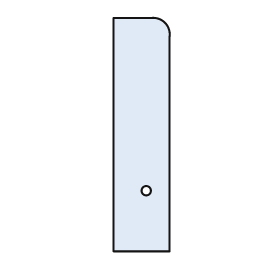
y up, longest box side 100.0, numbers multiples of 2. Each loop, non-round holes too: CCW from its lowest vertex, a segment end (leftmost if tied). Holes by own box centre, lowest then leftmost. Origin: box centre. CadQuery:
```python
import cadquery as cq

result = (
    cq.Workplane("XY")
    .moveTo(-12.0, -50.0)
    .lineTo(12.0, -50.0)
    .lineTo(12.0, 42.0)
    .threePointArc((10.0, 48.0), (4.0, 50.0))
    .lineTo(-12.0, 50.0)
    .close()
    .moveTo(2.0, -24.0)
    .circle(2.0)
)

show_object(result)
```